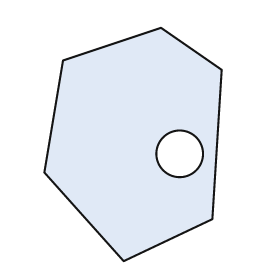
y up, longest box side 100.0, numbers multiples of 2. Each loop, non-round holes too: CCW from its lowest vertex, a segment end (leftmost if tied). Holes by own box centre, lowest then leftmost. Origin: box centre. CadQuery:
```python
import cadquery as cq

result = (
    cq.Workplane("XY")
    .moveTo(-4.0, -50.0)
    .lineTo(34.0, -32.0)
    .lineTo(38.0, 32.0)
    .lineTo(12.0, 50.0)
    .lineTo(-30.0, 36.0)
    .lineTo(-38.0, -12.0)
    .close()
    .moveTo(20.0, -4.0)
    .circle(10.0)
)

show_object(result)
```